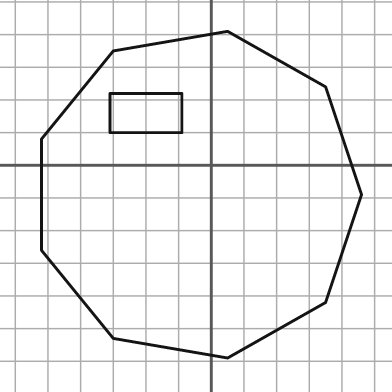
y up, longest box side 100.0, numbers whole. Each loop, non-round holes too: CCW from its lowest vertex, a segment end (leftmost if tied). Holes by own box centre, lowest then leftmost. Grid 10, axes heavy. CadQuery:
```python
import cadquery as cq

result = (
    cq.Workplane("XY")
    .moveTo(5.0, -59.0)
    .lineTo(35.0, -42.0)
    .lineTo(46.0, -9.0)
    .lineTo(35.0, 24.0)
    .lineTo(5.0, 41.0)
    .lineTo(-30.0, 35.0)
    .lineTo(-52.0, 8.0)
    .lineTo(-52.0, -26.0)
    .lineTo(-30.0, -53.0)
    .close()
    .moveTo(-31.0, 10.0)
    .lineTo(-9.0, 10.0)
    .lineTo(-9.0, 22.0)
    .lineTo(-31.0, 22.0)
    .close()
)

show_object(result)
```